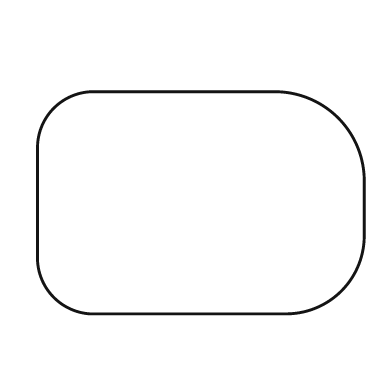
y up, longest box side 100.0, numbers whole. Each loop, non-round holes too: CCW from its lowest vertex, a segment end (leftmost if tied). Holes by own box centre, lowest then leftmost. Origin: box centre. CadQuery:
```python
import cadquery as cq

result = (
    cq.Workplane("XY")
    .moveTo(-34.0, -34.0)
    .lineTo(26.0, -34.0)
    .threePointArc((43.0, -27.0), (50.0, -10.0))
    .lineTo(50.0, 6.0)
    .threePointArc((42.0, 26.0), (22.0, 34.0))
    .lineTo(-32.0, 34.0)
    .threePointArc((-45.0, 29.0), (-50.0, 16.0))
    .lineTo(-50.0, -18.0)
    .threePointArc((-45.0, -29.0), (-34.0, -34.0))
    .close()
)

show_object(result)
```